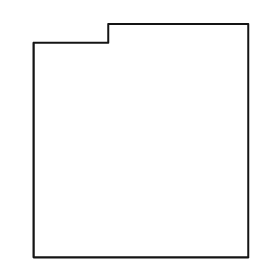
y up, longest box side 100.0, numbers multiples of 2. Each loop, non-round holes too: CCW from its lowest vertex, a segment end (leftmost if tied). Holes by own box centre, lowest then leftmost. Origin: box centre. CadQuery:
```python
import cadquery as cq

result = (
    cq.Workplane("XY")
    .moveTo(-46.0, -50.0)
    .lineTo(46.0, -50.0)
    .lineTo(46.0, 50.0)
    .lineTo(-14.0, 50.0)
    .lineTo(-14.0, 42.0)
    .lineTo(-46.0, 42.0)
    .close()
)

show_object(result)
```